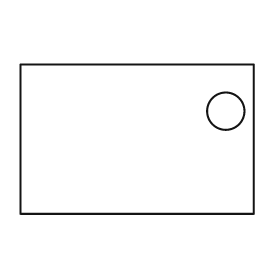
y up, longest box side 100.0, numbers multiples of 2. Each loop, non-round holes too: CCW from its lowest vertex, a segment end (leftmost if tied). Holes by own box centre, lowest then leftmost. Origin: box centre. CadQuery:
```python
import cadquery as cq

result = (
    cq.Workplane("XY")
    .moveTo(-50.0, -32.0)
    .lineTo(50.0, -32.0)
    .lineTo(50.0, 32.0)
    .lineTo(-50.0, 32.0)
    .close()
    .moveTo(38.0, 12.0)
    .circle(8.0)
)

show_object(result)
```